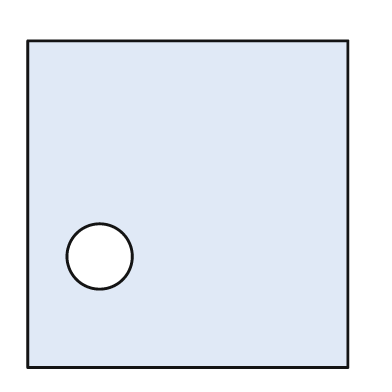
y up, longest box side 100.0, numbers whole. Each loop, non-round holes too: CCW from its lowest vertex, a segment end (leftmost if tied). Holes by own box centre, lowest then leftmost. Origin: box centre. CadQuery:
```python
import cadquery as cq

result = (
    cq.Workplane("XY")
    .moveTo(-49.0, -50.0)
    .lineTo(49.0, -50.0)
    .lineTo(49.0, 50.0)
    .lineTo(-49.0, 50.0)
    .close()
    .moveTo(-27.0, -16.0)
    .circle(10.0)
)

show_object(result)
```